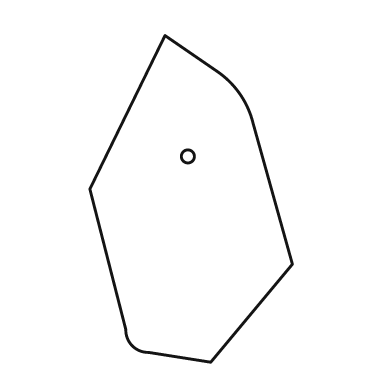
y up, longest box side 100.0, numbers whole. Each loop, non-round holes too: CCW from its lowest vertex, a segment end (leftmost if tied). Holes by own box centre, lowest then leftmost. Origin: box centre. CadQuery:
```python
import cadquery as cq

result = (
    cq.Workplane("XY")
    .moveTo(6.0, -50.0)
    .lineTo(31.0, -20.0)
    .lineTo(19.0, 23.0)
    .threePointArc((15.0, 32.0), (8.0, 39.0))
    .lineTo(-8.0, 50.0)
    .lineTo(-31.0, 3.0)
    .lineTo(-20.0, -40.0)
    .threePointArc((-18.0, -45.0), (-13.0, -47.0))
    .close()
    .moveTo(-1.0, 13.0)
    .circle(2.0)
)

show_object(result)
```